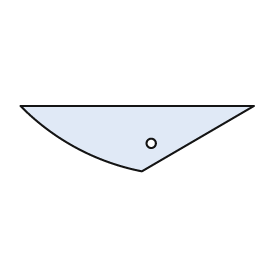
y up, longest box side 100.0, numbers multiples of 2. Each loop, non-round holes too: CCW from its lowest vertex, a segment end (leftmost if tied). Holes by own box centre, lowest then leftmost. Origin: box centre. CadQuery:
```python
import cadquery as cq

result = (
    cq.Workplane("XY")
    .moveTo(2.0, -14.0)
    .lineTo(50.0, 14.0)
    .lineTo(-50.0, 14.0)
    .threePointArc((-26.0, -4.0), (2.0, -14.0))
    .close()
    .moveTo(6.0, -2.0)
    .circle(2.0)
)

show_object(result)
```